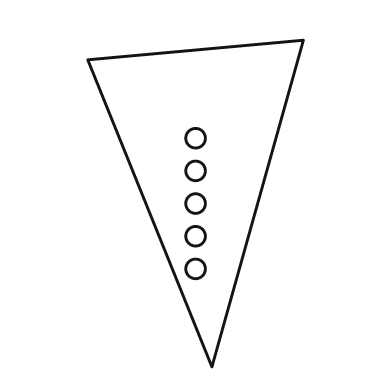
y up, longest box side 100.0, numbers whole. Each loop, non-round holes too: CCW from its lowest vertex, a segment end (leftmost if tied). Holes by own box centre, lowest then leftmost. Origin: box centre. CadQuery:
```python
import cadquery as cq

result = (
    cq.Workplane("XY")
    .moveTo(5.0, -50.0)
    .lineTo(33.0, 50.0)
    .lineTo(-33.0, 44.0)
    .close()
    .moveTo(0.0, -20.0)
    .circle(3.0)
    .moveTo(0.0, -10.0)
    .circle(3.0)
    .moveTo(0.0, 0.0)
    .circle(3.0)
    .moveTo(0.0, 10.0)
    .circle(3.0)
    .moveTo(0.0, 20.0)
    .circle(3.0)
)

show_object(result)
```